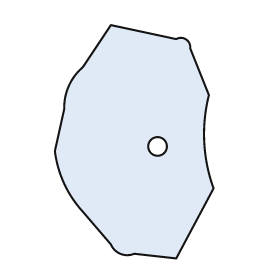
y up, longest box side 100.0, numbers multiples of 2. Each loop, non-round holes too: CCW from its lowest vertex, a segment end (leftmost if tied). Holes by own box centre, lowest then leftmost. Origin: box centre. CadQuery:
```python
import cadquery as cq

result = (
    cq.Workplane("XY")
    .moveTo(18.0, -50.0)
    .lineTo(34.0, -20.0)
    .threePointArc((30.0, 0.0), (32.0, 20.0))
    .lineTo(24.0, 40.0)
    .threePointArc((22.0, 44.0), (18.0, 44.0))
    .lineTo(-10.0, 50.0)
    .lineTo(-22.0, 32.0)
    .threePointArc((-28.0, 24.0), (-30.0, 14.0))
    .lineTo(-34.0, -4.0)
    .threePointArc((-30.0, -18.0), (-22.0, -30.0))
    .lineTo(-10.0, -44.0)
    .threePointArc((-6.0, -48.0), (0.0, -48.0))
    .close()
    .moveTo(10.0, -2.0)
    .circle(4.0)
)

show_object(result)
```